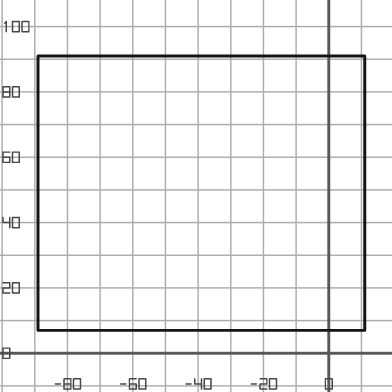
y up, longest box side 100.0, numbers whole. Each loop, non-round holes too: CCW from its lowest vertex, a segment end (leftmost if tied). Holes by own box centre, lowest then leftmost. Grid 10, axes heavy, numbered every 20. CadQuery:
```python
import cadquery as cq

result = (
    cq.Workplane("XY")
    .moveTo(-89.0, 7.0)
    .lineTo(11.0, 7.0)
    .lineTo(11.0, 91.0)
    .lineTo(-89.0, 91.0)
    .close()
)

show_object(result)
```